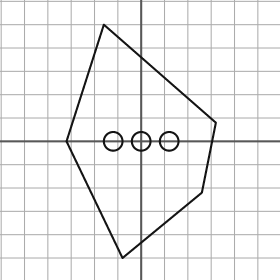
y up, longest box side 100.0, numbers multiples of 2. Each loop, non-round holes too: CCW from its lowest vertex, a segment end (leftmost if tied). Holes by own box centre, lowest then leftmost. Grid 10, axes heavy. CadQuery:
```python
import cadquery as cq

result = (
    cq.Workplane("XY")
    .moveTo(-8.0, -50.0)
    .lineTo(26.0, -22.0)
    .lineTo(32.0, 8.0)
    .lineTo(-16.0, 50.0)
    .lineTo(-32.0, 0.0)
    .close()
    .moveTo(-12.0, 0.0)
    .circle(4.0)
    .moveTo(0.0, 0.0)
    .circle(4.0)
    .moveTo(12.0, 0.0)
    .circle(4.0)
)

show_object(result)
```